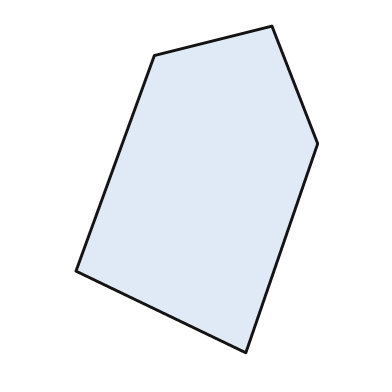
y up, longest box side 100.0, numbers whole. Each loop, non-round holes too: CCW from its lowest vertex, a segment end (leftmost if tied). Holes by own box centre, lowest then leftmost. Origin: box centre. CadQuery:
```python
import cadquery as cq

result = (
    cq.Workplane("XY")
    .moveTo(15.0, -50.0)
    .lineTo(37.0, 14.0)
    .lineTo(23.0, 50.0)
    .lineTo(-13.0, 41.0)
    .lineTo(-37.0, -25.0)
    .close()
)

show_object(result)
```